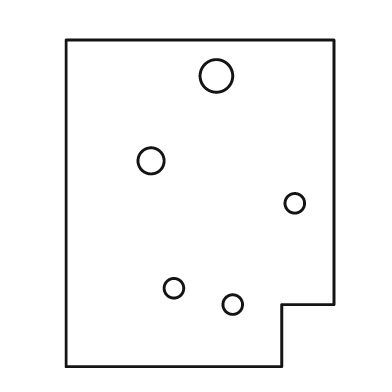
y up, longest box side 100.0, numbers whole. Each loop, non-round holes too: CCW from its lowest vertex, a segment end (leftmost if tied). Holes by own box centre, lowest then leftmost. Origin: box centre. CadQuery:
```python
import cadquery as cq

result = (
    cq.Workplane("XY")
    .moveTo(-41.0, -50.0)
    .lineTo(25.0, -50.0)
    .lineTo(25.0, -31.0)
    .lineTo(41.0, -31.0)
    .lineTo(41.0, 50.0)
    .lineTo(-41.0, 50.0)
    .close()
    .moveTo(10.0, -31.0)
    .circle(3.0)
    .moveTo(-8.0, -26.0)
    .circle(3.0)
    .moveTo(29.0, 0.0)
    .circle(3.0)
    .moveTo(-15.0, 13.0)
    .circle(4.0)
    .moveTo(5.0, 39.0)
    .circle(5.0)
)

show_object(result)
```